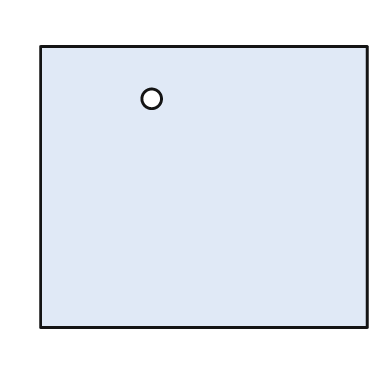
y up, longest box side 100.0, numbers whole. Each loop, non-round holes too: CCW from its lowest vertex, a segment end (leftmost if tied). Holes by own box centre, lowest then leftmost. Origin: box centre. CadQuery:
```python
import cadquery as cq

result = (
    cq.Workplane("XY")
    .moveTo(-50.0, -43.0)
    .lineTo(50.0, -43.0)
    .lineTo(50.0, 43.0)
    .lineTo(-50.0, 43.0)
    .close()
    .moveTo(-16.0, 27.0)
    .circle(3.0)
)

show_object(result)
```